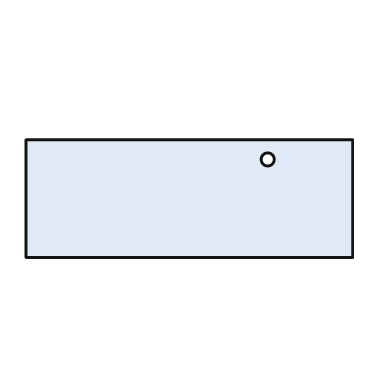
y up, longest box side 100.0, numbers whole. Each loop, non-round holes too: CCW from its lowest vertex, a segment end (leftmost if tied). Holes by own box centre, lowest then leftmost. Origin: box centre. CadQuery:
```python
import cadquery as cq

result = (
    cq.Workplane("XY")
    .moveTo(-50.0, -18.0)
    .lineTo(50.0, -18.0)
    .lineTo(50.0, 18.0)
    .lineTo(-50.0, 18.0)
    .close()
    .moveTo(24.0, 12.0)
    .circle(2.0)
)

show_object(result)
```